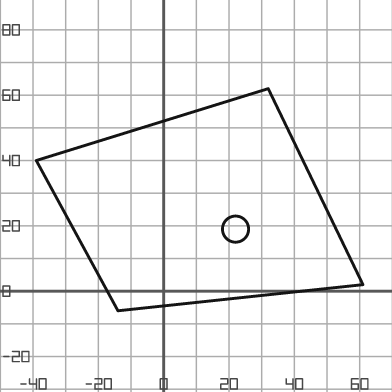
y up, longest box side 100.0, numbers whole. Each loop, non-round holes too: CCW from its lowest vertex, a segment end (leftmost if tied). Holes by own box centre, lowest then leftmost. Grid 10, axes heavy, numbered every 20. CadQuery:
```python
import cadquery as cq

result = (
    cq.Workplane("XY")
    .moveTo(-14.0, -6.0)
    .lineTo(61.0, 2.0)
    .lineTo(32.0, 62.0)
    .lineTo(-39.0, 40.0)
    .close()
    .moveTo(22.0, 19.0)
    .circle(4.0)
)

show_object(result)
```